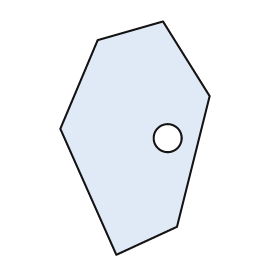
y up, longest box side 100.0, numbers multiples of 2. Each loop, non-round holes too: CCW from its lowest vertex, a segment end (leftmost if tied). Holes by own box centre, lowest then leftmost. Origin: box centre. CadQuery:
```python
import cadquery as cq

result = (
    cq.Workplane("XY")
    .moveTo(-8.0, -50.0)
    .lineTo(18.0, -38.0)
    .lineTo(32.0, 18.0)
    .lineTo(12.0, 50.0)
    .lineTo(-16.0, 42.0)
    .lineTo(-32.0, 4.0)
    .close()
    .moveTo(14.0, 0.0)
    .circle(6.0)
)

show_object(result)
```